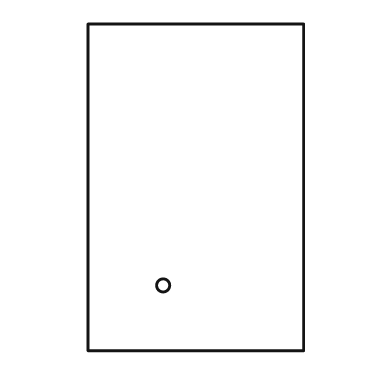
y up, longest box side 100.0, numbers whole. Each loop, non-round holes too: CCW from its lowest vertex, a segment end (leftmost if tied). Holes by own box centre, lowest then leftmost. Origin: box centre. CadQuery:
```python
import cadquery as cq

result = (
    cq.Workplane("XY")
    .moveTo(-33.0, -50.0)
    .lineTo(33.0, -50.0)
    .lineTo(33.0, 50.0)
    .lineTo(-33.0, 50.0)
    .close()
    .moveTo(-10.0, -30.0)
    .circle(2.0)
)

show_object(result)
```